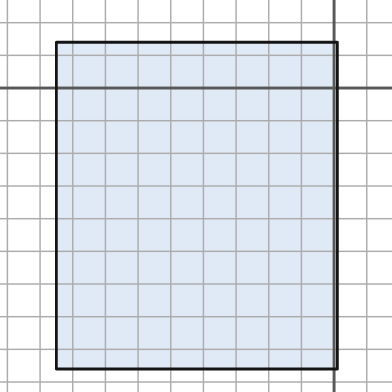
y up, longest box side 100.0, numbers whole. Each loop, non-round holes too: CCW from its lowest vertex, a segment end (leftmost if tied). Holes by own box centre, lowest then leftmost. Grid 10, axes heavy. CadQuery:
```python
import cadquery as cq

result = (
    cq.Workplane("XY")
    .moveTo(-85.0, -86.0)
    .lineTo(1.0, -86.0)
    .lineTo(1.0, 14.0)
    .lineTo(-85.0, 14.0)
    .close()
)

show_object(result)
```